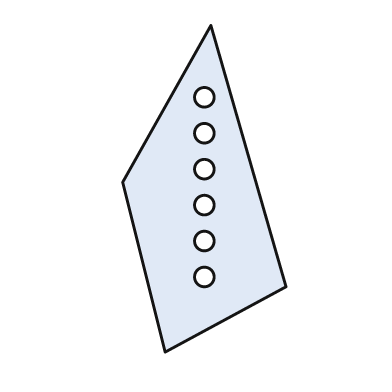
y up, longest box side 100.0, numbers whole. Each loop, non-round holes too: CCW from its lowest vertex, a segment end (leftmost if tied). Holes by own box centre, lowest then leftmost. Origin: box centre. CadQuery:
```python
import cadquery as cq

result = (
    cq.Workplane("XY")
    .moveTo(-12.0, -50.0)
    .lineTo(25.0, -30.0)
    .lineTo(2.0, 50.0)
    .lineTo(-25.0, 2.0)
    .close()
    .moveTo(0.0, -27.0)
    .circle(3.0)
    .moveTo(0.0, -16.0)
    .circle(3.0)
    .moveTo(0.0, -5.0)
    .circle(3.0)
    .moveTo(0.0, 6.0)
    .circle(3.0)
    .moveTo(0.0, 17.0)
    .circle(3.0)
    .moveTo(0.0, 28.0)
    .circle(3.0)
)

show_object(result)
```